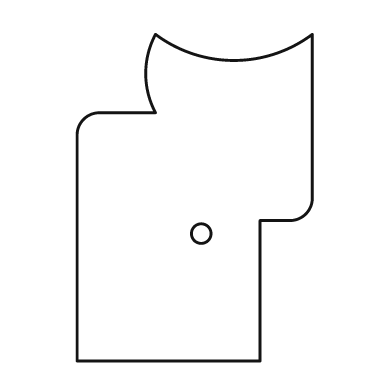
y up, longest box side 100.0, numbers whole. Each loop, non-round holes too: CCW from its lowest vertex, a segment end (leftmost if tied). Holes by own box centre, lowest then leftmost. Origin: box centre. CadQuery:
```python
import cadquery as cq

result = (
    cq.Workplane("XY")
    .moveTo(-36.0, -50.0)
    .lineTo(20.0, -50.0)
    .lineTo(20.0, -7.0)
    .lineTo(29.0, -7.0)
    .threePointArc((34.0, -5.0), (36.0, 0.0))
    .lineTo(36.0, 50.0)
    .threePointArc((12.0, 42.0), (-12.0, 50.0))
    .threePointArc((-15.0, 38.0), (-12.0, 26.0))
    .lineTo(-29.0, 26.0)
    .threePointArc((-34.0, 24.0), (-36.0, 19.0))
    .close()
    .moveTo(2.0, -11.0)
    .circle(3.0)
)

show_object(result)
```